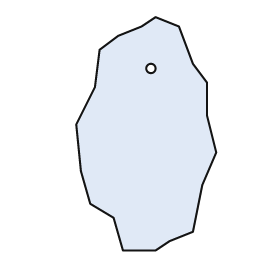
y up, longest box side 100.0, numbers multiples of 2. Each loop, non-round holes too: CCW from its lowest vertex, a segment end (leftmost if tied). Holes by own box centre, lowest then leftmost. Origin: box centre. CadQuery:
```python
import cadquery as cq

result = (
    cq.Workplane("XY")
    .moveTo(-10.0, -50.0)
    .lineTo(4.0, -50.0)
    .lineTo(10.0, -46.0)
    .lineTo(20.0, -42.0)
    .lineTo(24.0, -22.0)
    .lineTo(30.0, -8.0)
    .lineTo(26.0, 8.0)
    .lineTo(26.0, 22.0)
    .lineTo(20.0, 30.0)
    .lineTo(14.0, 46.0)
    .lineTo(4.0, 50.0)
    .lineTo(-2.0, 46.0)
    .lineTo(-12.0, 42.0)
    .lineTo(-20.0, 36.0)
    .lineTo(-22.0, 20.0)
    .lineTo(-30.0, 4.0)
    .lineTo(-28.0, -16.0)
    .lineTo(-24.0, -30.0)
    .lineTo(-14.0, -36.0)
    .close()
    .moveTo(2.0, 28.0)
    .circle(2.0)
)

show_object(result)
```